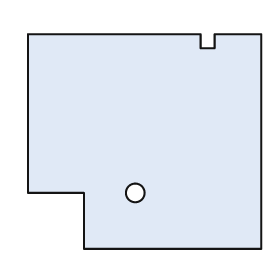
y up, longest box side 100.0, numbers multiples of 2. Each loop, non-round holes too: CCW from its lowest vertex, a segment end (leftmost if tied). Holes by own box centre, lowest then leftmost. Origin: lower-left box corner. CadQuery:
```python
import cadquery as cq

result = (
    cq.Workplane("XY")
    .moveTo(24.0, 0.0)
    .lineTo(100.0, 0.0)
    .lineTo(100.0, 92.0)
    .lineTo(80.0, 92.0)
    .lineTo(80.0, 86.0)
    .lineTo(74.0, 86.0)
    .lineTo(74.0, 92.0)
    .lineTo(0.0, 92.0)
    .lineTo(0.0, 24.0)
    .lineTo(24.0, 24.0)
    .close()
    .moveTo(46.0, 24.0)
    .circle(4.0)
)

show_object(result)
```